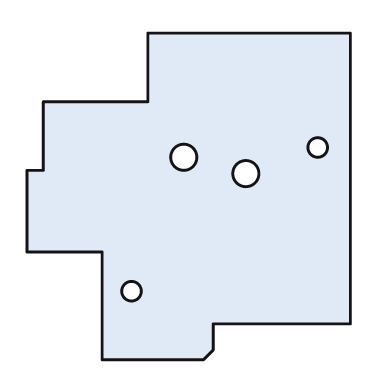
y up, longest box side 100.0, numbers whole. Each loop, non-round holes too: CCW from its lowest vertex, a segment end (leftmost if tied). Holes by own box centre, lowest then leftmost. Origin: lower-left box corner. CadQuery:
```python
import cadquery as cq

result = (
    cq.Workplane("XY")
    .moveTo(23.0, 0.0)
    .lineTo(54.0, 0.0)
    .lineTo(57.0, 3.0)
    .lineTo(57.0, 11.0)
    .lineTo(99.0, 11.0)
    .lineTo(99.0, 100.0)
    .lineTo(37.0, 100.0)
    .lineTo(37.0, 79.0)
    .lineTo(5.0, 79.0)
    .lineTo(5.0, 58.0)
    .lineTo(0.0, 58.0)
    .lineTo(0.0, 33.0)
    .lineTo(23.0, 33.0)
    .close()
    .moveTo(32.0, 21.0)
    .circle(3.0)
    .moveTo(67.0, 57.0)
    .circle(4.0)
    .moveTo(48.0, 62.0)
    .circle(4.0)
    .moveTo(89.0, 65.0)
    .circle(3.0)
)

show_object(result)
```